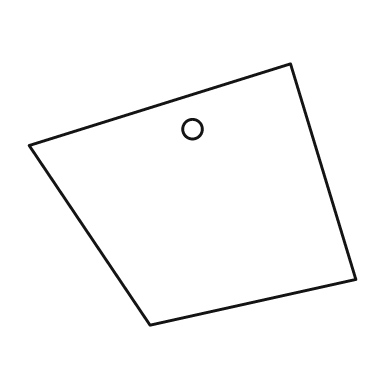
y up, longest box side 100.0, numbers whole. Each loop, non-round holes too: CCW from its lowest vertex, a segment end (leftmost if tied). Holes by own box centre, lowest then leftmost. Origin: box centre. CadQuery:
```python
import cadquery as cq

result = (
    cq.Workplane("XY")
    .moveTo(-13.0, -40.0)
    .lineTo(50.0, -26.0)
    .lineTo(30.0, 40.0)
    .lineTo(-50.0, 15.0)
    .close()
    .moveTo(0.0, 20.0)
    .circle(3.0)
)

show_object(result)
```